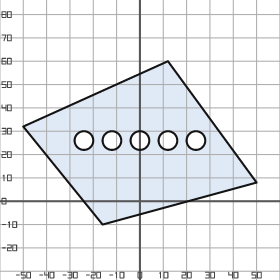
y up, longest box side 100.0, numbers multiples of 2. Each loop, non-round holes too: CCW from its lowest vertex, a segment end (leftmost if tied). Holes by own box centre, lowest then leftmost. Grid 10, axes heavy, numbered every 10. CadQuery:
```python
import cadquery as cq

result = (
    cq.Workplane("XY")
    .moveTo(-16.0, -10.0)
    .lineTo(50.0, 8.0)
    .lineTo(12.0, 60.0)
    .lineTo(-50.0, 32.0)
    .close()
    .moveTo(-24.0, 26.0)
    .circle(4.0)
    .moveTo(-12.0, 26.0)
    .circle(4.0)
    .moveTo(0.0, 26.0)
    .circle(4.0)
    .moveTo(12.0, 26.0)
    .circle(4.0)
    .moveTo(24.0, 26.0)
    .circle(4.0)
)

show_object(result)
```